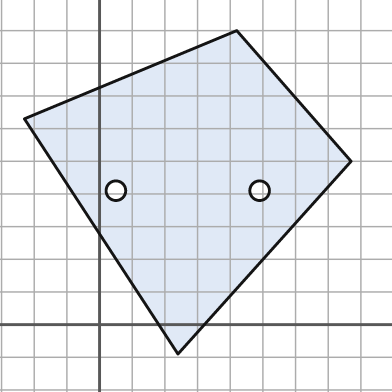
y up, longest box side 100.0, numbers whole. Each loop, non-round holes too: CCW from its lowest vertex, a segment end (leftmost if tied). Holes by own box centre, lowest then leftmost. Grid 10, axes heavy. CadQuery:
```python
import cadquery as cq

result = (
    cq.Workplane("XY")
    .moveTo(24.0, -9.0)
    .lineTo(77.0, 50.0)
    .lineTo(42.0, 90.0)
    .lineTo(-23.0, 63.0)
    .close()
    .moveTo(5.0, 41.0)
    .circle(3.0)
    .moveTo(49.0, 41.0)
    .circle(3.0)
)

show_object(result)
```